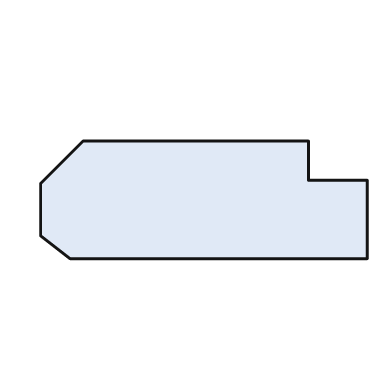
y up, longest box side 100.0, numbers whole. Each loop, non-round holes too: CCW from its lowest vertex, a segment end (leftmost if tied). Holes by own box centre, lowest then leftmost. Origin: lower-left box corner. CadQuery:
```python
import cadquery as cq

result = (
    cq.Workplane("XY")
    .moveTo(9.0, 0.0)
    .lineTo(100.0, 0.0)
    .lineTo(100.0, 24.0)
    .lineTo(82.0, 24.0)
    .lineTo(82.0, 36.0)
    .lineTo(13.0, 36.0)
    .lineTo(0.0, 23.0)
    .lineTo(0.0, 7.0)
    .close()
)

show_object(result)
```